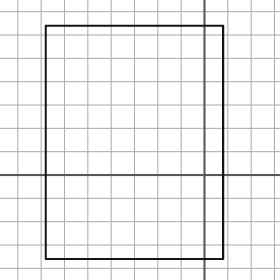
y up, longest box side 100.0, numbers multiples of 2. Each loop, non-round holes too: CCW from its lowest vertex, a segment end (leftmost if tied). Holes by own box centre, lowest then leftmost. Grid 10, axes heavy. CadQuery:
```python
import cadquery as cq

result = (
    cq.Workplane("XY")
    .moveTo(-68.0, -36.0)
    .lineTo(8.0, -36.0)
    .lineTo(8.0, 64.0)
    .lineTo(-68.0, 64.0)
    .close()
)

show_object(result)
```